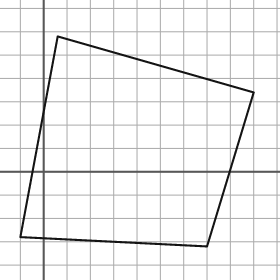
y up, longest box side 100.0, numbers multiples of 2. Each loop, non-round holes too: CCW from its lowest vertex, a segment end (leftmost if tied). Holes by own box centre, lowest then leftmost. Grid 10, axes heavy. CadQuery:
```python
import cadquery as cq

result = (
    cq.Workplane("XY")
    .moveTo(70.0, -32.0)
    .lineTo(90.0, 34.0)
    .lineTo(6.0, 58.0)
    .lineTo(-10.0, -28.0)
    .close()
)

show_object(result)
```